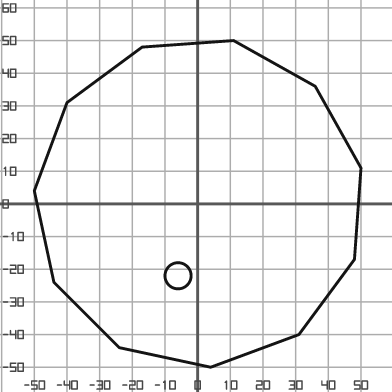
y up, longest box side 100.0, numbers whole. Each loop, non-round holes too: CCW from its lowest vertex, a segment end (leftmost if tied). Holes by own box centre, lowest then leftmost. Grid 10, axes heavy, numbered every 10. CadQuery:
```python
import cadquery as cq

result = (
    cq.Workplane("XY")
    .moveTo(4.0, -50.0)
    .lineTo(31.0, -40.0)
    .lineTo(48.0, -17.0)
    .lineTo(50.0, 11.0)
    .lineTo(36.0, 36.0)
    .lineTo(11.0, 50.0)
    .lineTo(-17.0, 48.0)
    .lineTo(-40.0, 31.0)
    .lineTo(-50.0, 4.0)
    .lineTo(-44.0, -24.0)
    .lineTo(-24.0, -44.0)
    .close()
    .moveTo(-6.0, -22.0)
    .circle(4.0)
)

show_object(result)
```